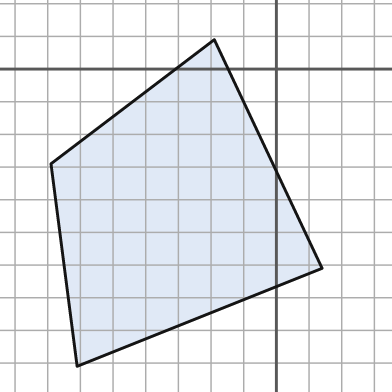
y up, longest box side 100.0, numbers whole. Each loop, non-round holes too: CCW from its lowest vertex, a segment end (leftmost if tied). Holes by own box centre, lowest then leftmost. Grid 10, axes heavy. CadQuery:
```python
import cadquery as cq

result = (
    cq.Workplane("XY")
    .moveTo(-61.0, -91.0)
    .lineTo(14.0, -61.0)
    .lineTo(-19.0, 9.0)
    .lineTo(-69.0, -29.0)
    .close()
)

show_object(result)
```